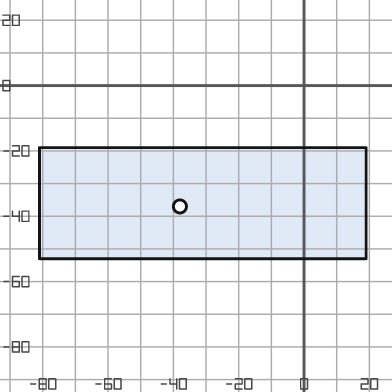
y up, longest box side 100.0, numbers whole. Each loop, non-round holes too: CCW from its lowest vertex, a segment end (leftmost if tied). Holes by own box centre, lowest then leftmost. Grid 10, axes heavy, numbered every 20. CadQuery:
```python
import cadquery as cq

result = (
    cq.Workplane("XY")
    .moveTo(-81.0, -53.0)
    .lineTo(19.0, -53.0)
    .lineTo(19.0, -19.0)
    .lineTo(-81.0, -19.0)
    .close()
    .moveTo(-38.0, -37.0)
    .circle(2.0)
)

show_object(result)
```